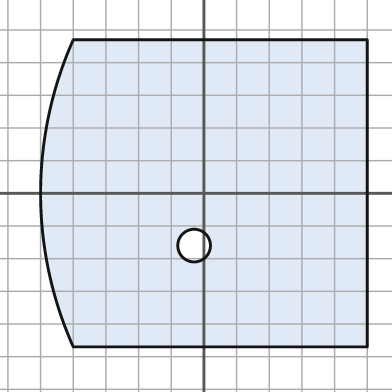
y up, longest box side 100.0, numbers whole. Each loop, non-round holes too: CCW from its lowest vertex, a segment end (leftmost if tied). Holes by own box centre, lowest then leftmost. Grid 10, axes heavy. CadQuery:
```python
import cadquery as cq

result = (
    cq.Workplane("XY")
    .moveTo(-40.0, -47.0)
    .lineTo(50.0, -47.0)
    .lineTo(50.0, 47.0)
    .lineTo(-40.0, 47.0)
    .threePointArc((-50.0, 0.0), (-40.0, -47.0))
    .close()
    .moveTo(-3.0, -16.0)
    .circle(5.0)
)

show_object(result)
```